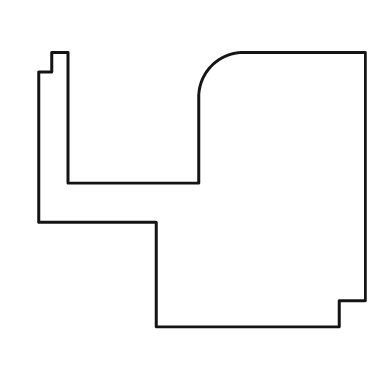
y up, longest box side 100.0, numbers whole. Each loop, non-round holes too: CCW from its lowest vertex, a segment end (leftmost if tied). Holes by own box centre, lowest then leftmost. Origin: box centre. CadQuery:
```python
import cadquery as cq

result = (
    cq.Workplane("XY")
    .moveTo(-14.0, -42.0)
    .lineTo(42.0, -42.0)
    .lineTo(42.0, -34.0)
    .lineTo(50.0, -34.0)
    .lineTo(50.0, 42.0)
    .lineTo(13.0, 42.0)
    .threePointArc((3.0, 38.0), (-1.0, 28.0))
    .lineTo(-1.0, 2.0)
    .lineTo(-41.0, 2.0)
    .lineTo(-41.0, 42.0)
    .lineTo(-46.0, 42.0)
    .lineTo(-46.0, 36.0)
    .lineTo(-50.0, 36.0)
    .lineTo(-50.0, -10.0)
    .lineTo(-14.0, -10.0)
    .close()
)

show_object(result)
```